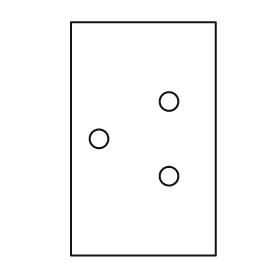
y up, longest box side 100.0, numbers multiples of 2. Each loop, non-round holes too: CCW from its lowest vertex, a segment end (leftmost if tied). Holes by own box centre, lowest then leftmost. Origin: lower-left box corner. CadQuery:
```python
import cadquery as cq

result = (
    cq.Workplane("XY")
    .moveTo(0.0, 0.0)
    .lineTo(62.0, 0.0)
    .lineTo(62.0, 100.0)
    .lineTo(0.0, 100.0)
    .close()
    .moveTo(42.0, 34.0)
    .circle(4.0)
    .moveTo(12.0, 50.0)
    .circle(4.0)
    .moveTo(42.0, 66.0)
    .circle(4.0)
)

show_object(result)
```